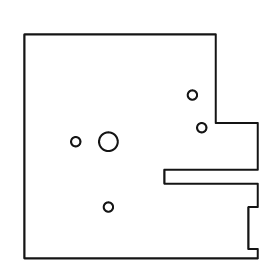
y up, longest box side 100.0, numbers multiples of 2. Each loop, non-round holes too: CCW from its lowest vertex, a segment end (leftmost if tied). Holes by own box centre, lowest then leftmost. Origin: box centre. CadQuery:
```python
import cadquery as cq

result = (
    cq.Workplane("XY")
    .moveTo(-50.0, -48.0)
    .lineTo(50.0, -48.0)
    .lineTo(50.0, -44.0)
    .lineTo(46.0, -44.0)
    .lineTo(46.0, -26.0)
    .lineTo(50.0, -26.0)
    .lineTo(50.0, -16.0)
    .lineTo(10.0, -16.0)
    .lineTo(10.0, -10.0)
    .lineTo(50.0, -10.0)
    .lineTo(50.0, 10.0)
    .lineTo(32.0, 10.0)
    .lineTo(32.0, 48.0)
    .lineTo(-50.0, 48.0)
    .close()
    .moveTo(-14.0, -26.0)
    .circle(2.0)
    .moveTo(-28.0, 2.0)
    .circle(2.0)
    .moveTo(-14.0, 2.0)
    .circle(4.0)
    .moveTo(26.0, 8.0)
    .circle(2.0)
    .moveTo(22.0, 22.0)
    .circle(2.0)
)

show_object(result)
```